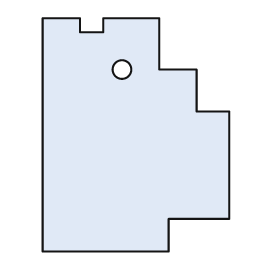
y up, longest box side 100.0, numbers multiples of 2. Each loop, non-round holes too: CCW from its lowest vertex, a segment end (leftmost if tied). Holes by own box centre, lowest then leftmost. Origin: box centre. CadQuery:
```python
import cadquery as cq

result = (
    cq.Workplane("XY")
    .moveTo(-40.0, -50.0)
    .lineTo(14.0, -50.0)
    .lineTo(14.0, -36.0)
    .lineTo(40.0, -36.0)
    .lineTo(40.0, 10.0)
    .lineTo(26.0, 10.0)
    .lineTo(26.0, 28.0)
    .lineTo(10.0, 28.0)
    .lineTo(10.0, 50.0)
    .lineTo(-14.0, 50.0)
    .lineTo(-14.0, 44.0)
    .lineTo(-24.0, 44.0)
    .lineTo(-24.0, 50.0)
    .lineTo(-40.0, 50.0)
    .close()
    .moveTo(-6.0, 28.0)
    .circle(4.0)
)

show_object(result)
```